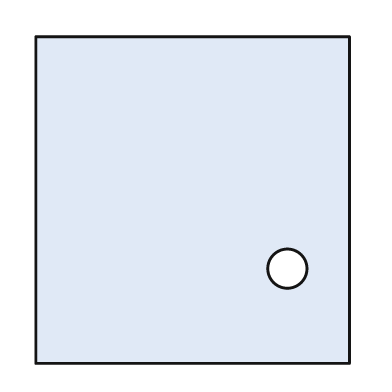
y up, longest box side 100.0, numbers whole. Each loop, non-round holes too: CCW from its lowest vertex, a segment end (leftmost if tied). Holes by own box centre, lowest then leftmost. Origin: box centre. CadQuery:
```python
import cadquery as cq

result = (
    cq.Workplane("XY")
    .moveTo(-48.0, -50.0)
    .lineTo(48.0, -50.0)
    .lineTo(48.0, 50.0)
    .lineTo(-48.0, 50.0)
    .close()
    .moveTo(29.0, -21.0)
    .circle(6.0)
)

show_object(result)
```